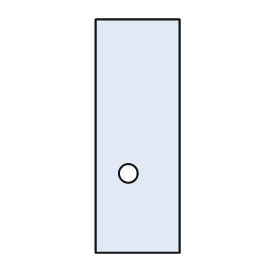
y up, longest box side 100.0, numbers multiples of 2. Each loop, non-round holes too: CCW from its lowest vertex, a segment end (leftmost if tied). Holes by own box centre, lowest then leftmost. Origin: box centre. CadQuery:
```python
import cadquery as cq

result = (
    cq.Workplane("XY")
    .moveTo(-18.0, -50.0)
    .lineTo(18.0, -50.0)
    .lineTo(18.0, 50.0)
    .lineTo(-18.0, 50.0)
    .close()
    .moveTo(-4.0, -16.0)
    .circle(4.0)
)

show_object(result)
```